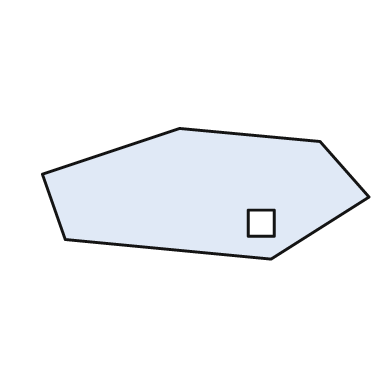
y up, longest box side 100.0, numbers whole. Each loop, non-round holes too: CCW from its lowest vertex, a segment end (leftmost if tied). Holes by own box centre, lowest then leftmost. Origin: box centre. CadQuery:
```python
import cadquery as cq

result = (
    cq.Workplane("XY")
    .moveTo(20.0, -20.0)
    .lineTo(50.0, -1.0)
    .lineTo(35.0, 16.0)
    .lineTo(-8.0, 20.0)
    .lineTo(-50.0, 6.0)
    .lineTo(-43.0, -14.0)
    .close()
    .moveTo(13.0, -13.0)
    .lineTo(21.0, -13.0)
    .lineTo(21.0, -5.0)
    .lineTo(13.0, -5.0)
    .close()
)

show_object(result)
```